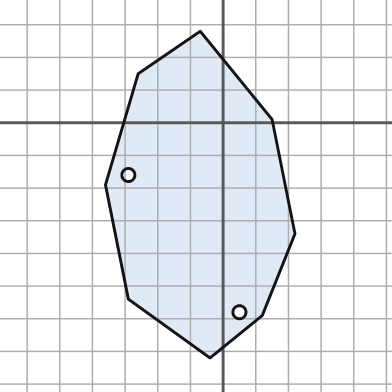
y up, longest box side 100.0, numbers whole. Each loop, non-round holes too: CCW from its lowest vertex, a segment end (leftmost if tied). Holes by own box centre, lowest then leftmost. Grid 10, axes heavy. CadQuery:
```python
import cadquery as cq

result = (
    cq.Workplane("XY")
    .moveTo(-4.0, -72.0)
    .lineTo(12.0, -59.0)
    .lineTo(22.0, -34.0)
    .lineTo(15.0, 1.0)
    .lineTo(-7.0, 28.0)
    .lineTo(-26.0, 15.0)
    .lineTo(-36.0, -19.0)
    .lineTo(-29.0, -54.0)
    .close()
    .moveTo(5.0, -58.0)
    .circle(2.0)
    .moveTo(-29.0, -16.0)
    .circle(2.0)
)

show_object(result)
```